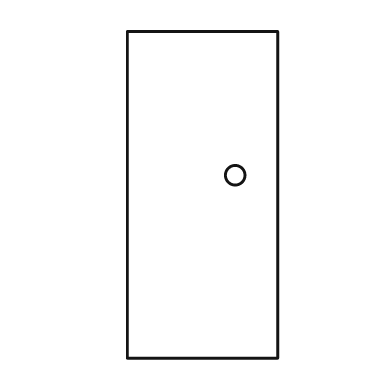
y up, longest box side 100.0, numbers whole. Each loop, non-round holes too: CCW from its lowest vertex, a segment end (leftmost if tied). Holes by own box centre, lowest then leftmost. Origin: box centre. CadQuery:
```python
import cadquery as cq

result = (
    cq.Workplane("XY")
    .moveTo(-23.0, -50.0)
    .lineTo(23.0, -50.0)
    .lineTo(23.0, 50.0)
    .lineTo(-23.0, 50.0)
    .close()
    .moveTo(10.0, 6.0)
    .circle(3.0)
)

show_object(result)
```